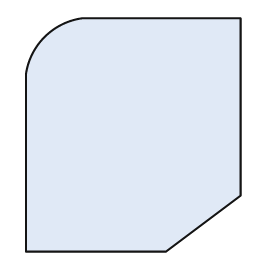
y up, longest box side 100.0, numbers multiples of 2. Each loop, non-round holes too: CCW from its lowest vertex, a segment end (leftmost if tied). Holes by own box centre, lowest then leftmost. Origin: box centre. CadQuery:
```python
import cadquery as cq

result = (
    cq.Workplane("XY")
    .moveTo(-46.0, -50.0)
    .lineTo(14.0, -50.0)
    .lineTo(46.0, -26.0)
    .lineTo(46.0, 50.0)
    .lineTo(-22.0, 50.0)
    .threePointArc((-38.0, 42.0), (-46.0, 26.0))
    .close()
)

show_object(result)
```